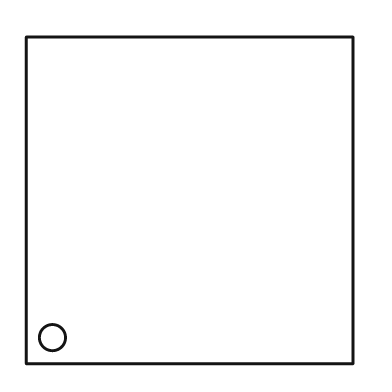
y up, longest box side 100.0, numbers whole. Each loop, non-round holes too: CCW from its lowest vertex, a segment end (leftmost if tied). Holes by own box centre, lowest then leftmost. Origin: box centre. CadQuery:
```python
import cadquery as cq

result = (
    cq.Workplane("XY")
    .moveTo(-50.0, -50.0)
    .lineTo(50.0, -50.0)
    .lineTo(50.0, 50.0)
    .lineTo(-50.0, 50.0)
    .close()
    .moveTo(-42.0, -42.0)
    .circle(4.0)
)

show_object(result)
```